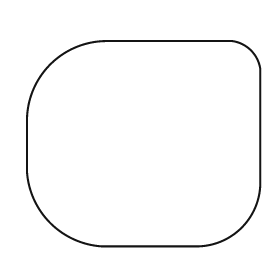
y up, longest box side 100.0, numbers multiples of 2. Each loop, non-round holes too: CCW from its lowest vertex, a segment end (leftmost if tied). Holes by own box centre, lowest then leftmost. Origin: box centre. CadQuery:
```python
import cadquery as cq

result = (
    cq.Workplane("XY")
    .moveTo(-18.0, -44.0)
    .lineTo(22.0, -44.0)
    .threePointArc((42.0, -36.0), (50.0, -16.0))
    .lineTo(50.0, 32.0)
    .threePointArc((46.0, 40.0), (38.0, 44.0))
    .lineTo(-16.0, 44.0)
    .threePointArc((-40.0, 34.0), (-50.0, 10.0))
    .lineTo(-50.0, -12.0)
    .threePointArc((-40.0, -34.0), (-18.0, -44.0))
    .close()
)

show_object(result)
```